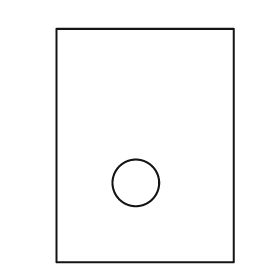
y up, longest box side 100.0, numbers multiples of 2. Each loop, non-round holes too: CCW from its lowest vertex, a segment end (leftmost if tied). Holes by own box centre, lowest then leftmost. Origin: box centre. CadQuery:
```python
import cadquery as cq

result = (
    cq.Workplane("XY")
    .moveTo(-38.0, -50.0)
    .lineTo(38.0, -50.0)
    .lineTo(38.0, 50.0)
    .lineTo(-38.0, 50.0)
    .close()
    .moveTo(-4.0, -16.0)
    .circle(10.0)
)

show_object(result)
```